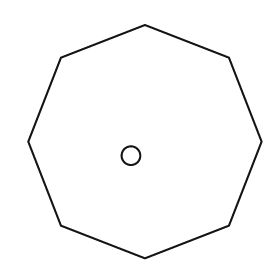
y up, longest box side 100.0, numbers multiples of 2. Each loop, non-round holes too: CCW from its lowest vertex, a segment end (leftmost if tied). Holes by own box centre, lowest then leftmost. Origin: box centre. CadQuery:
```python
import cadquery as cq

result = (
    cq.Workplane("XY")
    .moveTo(0.0, -50.0)
    .lineTo(36.0, -36.0)
    .lineTo(50.0, 0.0)
    .lineTo(36.0, 36.0)
    .lineTo(0.0, 50.0)
    .lineTo(-36.0, 36.0)
    .lineTo(-50.0, 0.0)
    .lineTo(-36.0, -36.0)
    .close()
    .moveTo(-6.0, -6.0)
    .circle(4.0)
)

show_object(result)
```